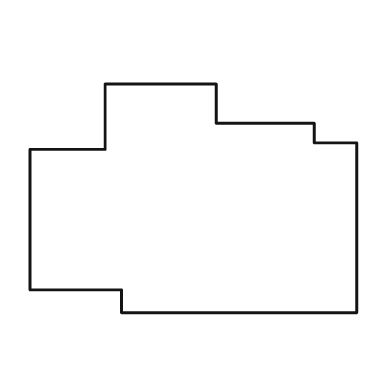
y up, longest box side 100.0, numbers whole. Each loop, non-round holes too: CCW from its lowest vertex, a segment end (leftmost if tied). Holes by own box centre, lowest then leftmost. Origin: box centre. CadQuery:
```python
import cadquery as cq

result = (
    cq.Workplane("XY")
    .moveTo(-22.0, -35.0)
    .lineTo(50.0, -35.0)
    .lineTo(50.0, 17.0)
    .lineTo(37.0, 17.0)
    .lineTo(37.0, 23.0)
    .lineTo(7.0, 23.0)
    .lineTo(7.0, 35.0)
    .lineTo(-27.0, 35.0)
    .lineTo(-27.0, 15.0)
    .lineTo(-50.0, 15.0)
    .lineTo(-50.0, -28.0)
    .lineTo(-22.0, -28.0)
    .close()
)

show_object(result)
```